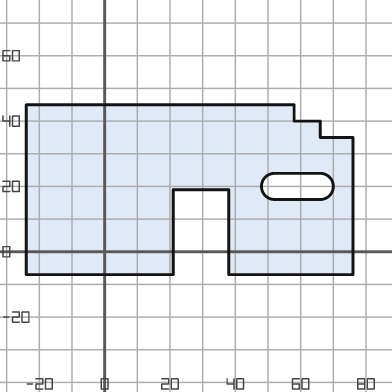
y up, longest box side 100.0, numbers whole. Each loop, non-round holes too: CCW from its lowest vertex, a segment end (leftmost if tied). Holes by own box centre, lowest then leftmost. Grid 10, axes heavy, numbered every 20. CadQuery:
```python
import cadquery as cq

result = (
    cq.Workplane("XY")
    .moveTo(-24.0, -7.0)
    .lineTo(21.0, -7.0)
    .lineTo(21.0, 19.0)
    .lineTo(38.0, 19.0)
    .lineTo(38.0, -7.0)
    .lineTo(76.0, -7.0)
    .lineTo(76.0, 35.0)
    .lineTo(66.0, 35.0)
    .lineTo(66.0, 40.0)
    .lineTo(58.0, 40.0)
    .lineTo(58.0, 45.0)
    .lineTo(-24.0, 45.0)
    .close()
    .moveTo(52.0, 16.0)
    .lineTo(66.0, 16.0)
    .threePointArc((70.0, 20.0), (66.0, 24.0))
    .lineTo(52.0, 24.0)
    .threePointArc((48.0, 20.0), (52.0, 16.0))
    .close()
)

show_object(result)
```